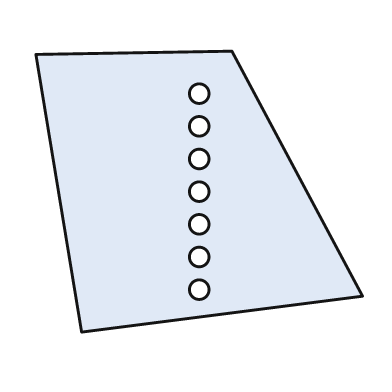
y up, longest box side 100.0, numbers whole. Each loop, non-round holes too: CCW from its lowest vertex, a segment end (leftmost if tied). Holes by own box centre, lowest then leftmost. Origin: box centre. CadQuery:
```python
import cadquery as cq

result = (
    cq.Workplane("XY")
    .moveTo(-36.0, -43.0)
    .lineTo(50.0, -32.0)
    .lineTo(10.0, 43.0)
    .lineTo(-50.0, 42.0)
    .close()
    .moveTo(0.0, -30.0)
    .circle(3.0)
    .moveTo(0.0, -20.0)
    .circle(3.0)
    .moveTo(0.0, -10.0)
    .circle(3.0)
    .moveTo(0.0, 0.0)
    .circle(3.0)
    .moveTo(0.0, 10.0)
    .circle(3.0)
    .moveTo(0.0, 20.0)
    .circle(3.0)
    .moveTo(0.0, 30.0)
    .circle(3.0)
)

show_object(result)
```